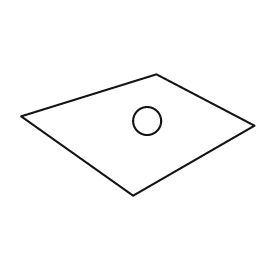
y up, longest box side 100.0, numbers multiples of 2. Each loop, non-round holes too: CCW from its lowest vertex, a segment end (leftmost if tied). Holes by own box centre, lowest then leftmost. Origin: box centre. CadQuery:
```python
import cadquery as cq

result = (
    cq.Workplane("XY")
    .moveTo(-2.0, -26.0)
    .lineTo(50.0, 4.0)
    .lineTo(8.0, 26.0)
    .lineTo(-50.0, 8.0)
    .close()
    .moveTo(4.0, 6.0)
    .circle(6.0)
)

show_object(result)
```